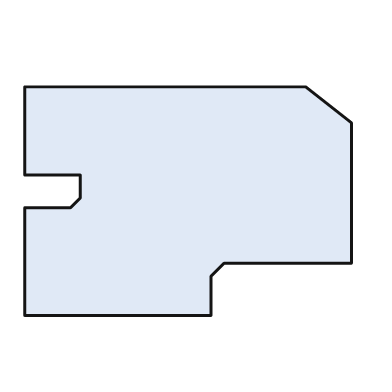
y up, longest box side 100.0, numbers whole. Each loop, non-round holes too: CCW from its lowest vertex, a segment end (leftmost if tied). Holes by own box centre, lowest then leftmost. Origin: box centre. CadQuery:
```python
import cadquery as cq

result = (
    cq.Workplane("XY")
    .moveTo(-50.0, -35.0)
    .lineTo(7.0, -35.0)
    .lineTo(7.0, -23.0)
    .lineTo(11.0, -19.0)
    .lineTo(50.0, -19.0)
    .lineTo(50.0, 24.0)
    .lineTo(36.0, 35.0)
    .lineTo(-50.0, 35.0)
    .lineTo(-50.0, 8.0)
    .lineTo(-33.0, 8.0)
    .lineTo(-33.0, 1.0)
    .lineTo(-36.0, -2.0)
    .lineTo(-50.0, -2.0)
    .close()
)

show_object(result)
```